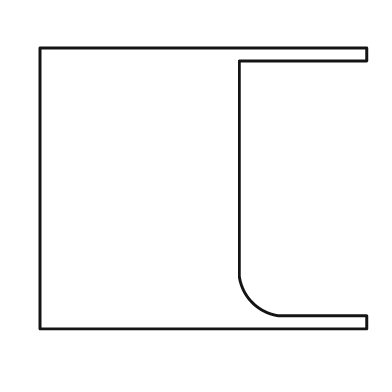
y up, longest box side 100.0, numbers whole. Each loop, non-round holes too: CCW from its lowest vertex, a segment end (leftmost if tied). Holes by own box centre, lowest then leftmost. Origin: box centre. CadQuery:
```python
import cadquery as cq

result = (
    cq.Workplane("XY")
    .moveTo(-50.0, -43.0)
    .lineTo(50.0, -43.0)
    .lineTo(50.0, -39.0)
    .lineTo(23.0, -39.0)
    .threePointArc((15.0, -35.0), (11.0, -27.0))
    .lineTo(11.0, 39.0)
    .lineTo(50.0, 39.0)
    .lineTo(50.0, 43.0)
    .lineTo(-50.0, 43.0)
    .close()
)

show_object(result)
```